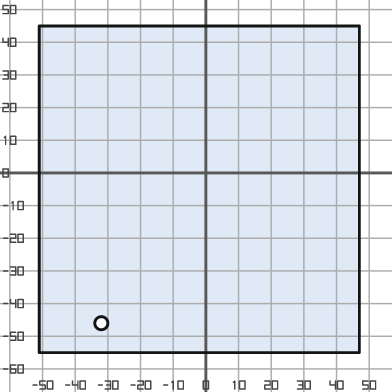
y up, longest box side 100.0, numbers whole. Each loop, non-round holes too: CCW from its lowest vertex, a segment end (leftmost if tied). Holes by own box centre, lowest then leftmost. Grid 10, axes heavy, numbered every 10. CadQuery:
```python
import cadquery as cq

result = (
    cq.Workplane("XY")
    .moveTo(-51.0, -55.0)
    .lineTo(47.0, -55.0)
    .lineTo(47.0, 45.0)
    .lineTo(-51.0, 45.0)
    .close()
    .moveTo(-32.0, -46.0)
    .circle(2.0)
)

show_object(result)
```